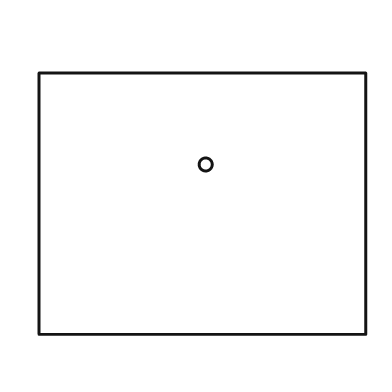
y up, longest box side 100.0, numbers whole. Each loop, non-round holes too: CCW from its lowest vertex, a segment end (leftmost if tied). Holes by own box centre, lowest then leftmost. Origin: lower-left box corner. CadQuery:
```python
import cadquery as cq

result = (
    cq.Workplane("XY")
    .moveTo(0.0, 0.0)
    .lineTo(100.0, 0.0)
    .lineTo(100.0, 80.0)
    .lineTo(0.0, 80.0)
    .close()
    .moveTo(51.0, 52.0)
    .circle(2.0)
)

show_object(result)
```